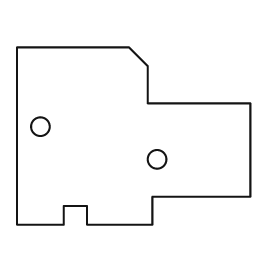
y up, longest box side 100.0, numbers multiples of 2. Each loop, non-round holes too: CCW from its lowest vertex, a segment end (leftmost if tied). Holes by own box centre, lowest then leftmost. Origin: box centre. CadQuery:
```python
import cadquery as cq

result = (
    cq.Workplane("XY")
    .moveTo(-50.0, -38.0)
    .lineTo(-30.0, -38.0)
    .lineTo(-30.0, -30.0)
    .lineTo(-20.0, -30.0)
    .lineTo(-20.0, -38.0)
    .lineTo(8.0, -38.0)
    .lineTo(8.0, -26.0)
    .lineTo(50.0, -26.0)
    .lineTo(50.0, 14.0)
    .lineTo(6.0, 14.0)
    .lineTo(6.0, 30.0)
    .lineTo(-2.0, 38.0)
    .lineTo(-50.0, 38.0)
    .close()
    .moveTo(10.0, -10.0)
    .circle(4.0)
    .moveTo(-40.0, 4.0)
    .circle(4.0)
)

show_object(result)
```